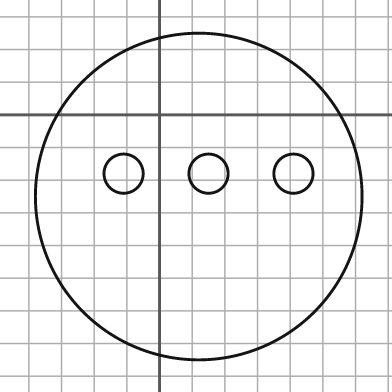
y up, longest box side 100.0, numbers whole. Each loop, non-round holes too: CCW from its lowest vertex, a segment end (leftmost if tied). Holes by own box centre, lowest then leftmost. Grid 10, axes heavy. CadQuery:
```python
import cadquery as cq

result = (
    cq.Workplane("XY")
    .moveTo(12.0, -25.0)
    .circle(50.0)
    .moveTo(-11.0, -18.0)
    .circle(6.0)
    .moveTo(15.0, -18.0)
    .circle(6.0)
    .moveTo(41.0, -18.0)
    .circle(6.0)
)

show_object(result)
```